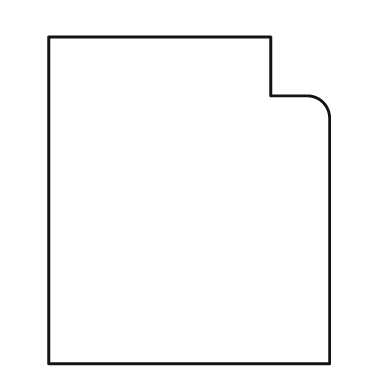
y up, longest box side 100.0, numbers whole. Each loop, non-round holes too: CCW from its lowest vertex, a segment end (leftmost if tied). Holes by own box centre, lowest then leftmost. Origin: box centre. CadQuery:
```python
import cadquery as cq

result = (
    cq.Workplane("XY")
    .moveTo(-43.0, -50.0)
    .lineTo(43.0, -50.0)
    .lineTo(43.0, 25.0)
    .threePointArc((41.0, 30.0), (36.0, 32.0))
    .lineTo(25.0, 32.0)
    .lineTo(25.0, 50.0)
    .lineTo(-43.0, 50.0)
    .close()
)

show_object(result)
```